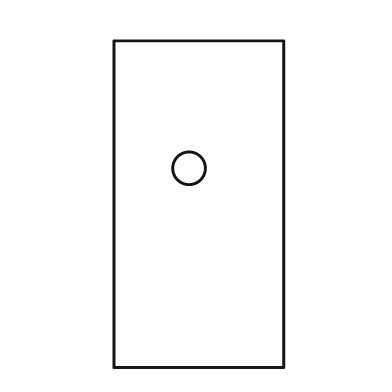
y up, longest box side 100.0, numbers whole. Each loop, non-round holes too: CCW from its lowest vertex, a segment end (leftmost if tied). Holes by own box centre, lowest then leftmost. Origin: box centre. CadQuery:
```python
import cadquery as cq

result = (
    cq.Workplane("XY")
    .moveTo(-26.0, -50.0)
    .lineTo(26.0, -50.0)
    .lineTo(26.0, 50.0)
    .lineTo(-26.0, 50.0)
    .close()
    .moveTo(-3.0, 11.0)
    .circle(5.0)
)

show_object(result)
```